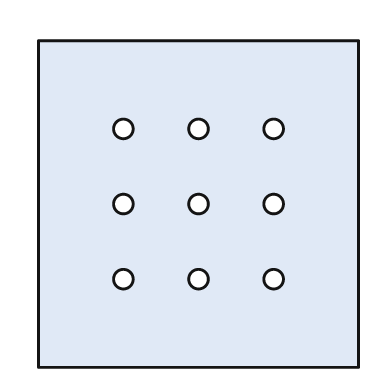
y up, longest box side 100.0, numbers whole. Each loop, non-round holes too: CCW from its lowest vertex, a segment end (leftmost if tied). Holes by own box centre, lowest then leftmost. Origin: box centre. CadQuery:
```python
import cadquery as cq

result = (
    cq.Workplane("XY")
    .moveTo(-49.0, -50.0)
    .lineTo(49.0, -50.0)
    .lineTo(49.0, 50.0)
    .lineTo(-49.0, 50.0)
    .close()
    .moveTo(-23.0, -23.0)
    .circle(3.0)
    .moveTo(0.0, -23.0)
    .circle(3.0)
    .moveTo(23.0, -23.0)
    .circle(3.0)
    .moveTo(-23.0, 0.0)
    .circle(3.0)
    .moveTo(0.0, 0.0)
    .circle(3.0)
    .moveTo(23.0, 0.0)
    .circle(3.0)
    .moveTo(-23.0, 23.0)
    .circle(3.0)
    .moveTo(0.0, 23.0)
    .circle(3.0)
    .moveTo(23.0, 23.0)
    .circle(3.0)
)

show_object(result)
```